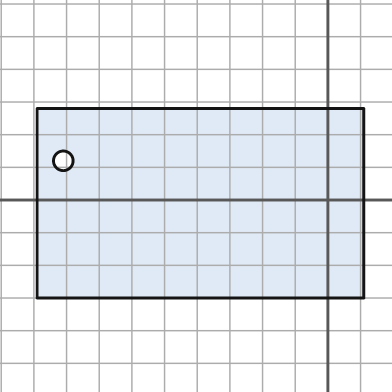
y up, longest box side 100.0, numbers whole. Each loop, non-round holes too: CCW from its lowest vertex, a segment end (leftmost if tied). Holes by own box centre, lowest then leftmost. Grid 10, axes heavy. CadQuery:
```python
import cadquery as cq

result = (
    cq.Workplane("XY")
    .moveTo(-89.0, -30.0)
    .lineTo(11.0, -30.0)
    .lineTo(11.0, 28.0)
    .lineTo(-89.0, 28.0)
    .close()
    .moveTo(-81.0, 12.0)
    .circle(3.0)
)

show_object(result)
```